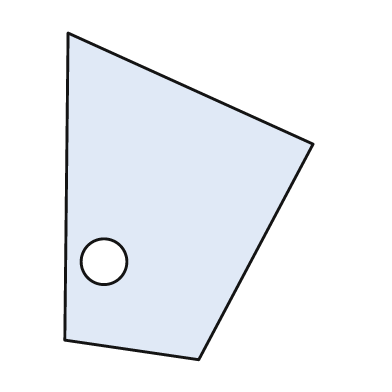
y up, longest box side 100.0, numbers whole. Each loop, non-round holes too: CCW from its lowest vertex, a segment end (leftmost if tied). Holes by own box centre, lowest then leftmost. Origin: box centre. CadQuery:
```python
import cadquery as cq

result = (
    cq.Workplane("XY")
    .moveTo(3.0, -50.0)
    .lineTo(38.0, 16.0)
    .lineTo(-37.0, 50.0)
    .lineTo(-38.0, -44.0)
    .close()
    .moveTo(-26.0, -20.0)
    .circle(7.0)
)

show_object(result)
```